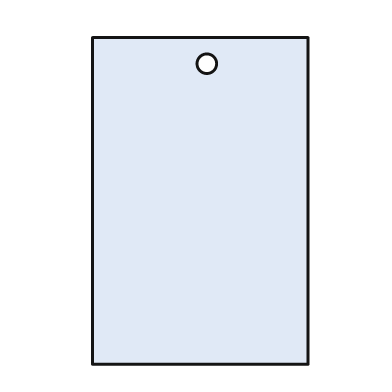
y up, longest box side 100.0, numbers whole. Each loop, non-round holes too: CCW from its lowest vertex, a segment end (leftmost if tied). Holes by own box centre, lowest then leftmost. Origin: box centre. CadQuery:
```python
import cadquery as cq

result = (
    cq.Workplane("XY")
    .moveTo(-33.0, -50.0)
    .lineTo(33.0, -50.0)
    .lineTo(33.0, 50.0)
    .lineTo(-33.0, 50.0)
    .close()
    .moveTo(2.0, 42.0)
    .circle(3.0)
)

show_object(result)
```